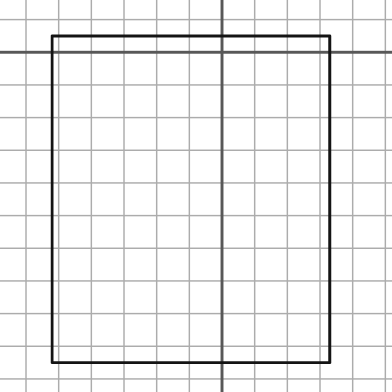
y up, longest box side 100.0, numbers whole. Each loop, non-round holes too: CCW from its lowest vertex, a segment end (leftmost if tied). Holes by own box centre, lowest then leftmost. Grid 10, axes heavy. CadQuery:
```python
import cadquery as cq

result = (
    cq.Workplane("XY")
    .moveTo(-52.0, -95.0)
    .lineTo(33.0, -95.0)
    .lineTo(33.0, 5.0)
    .lineTo(-52.0, 5.0)
    .close()
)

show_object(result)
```